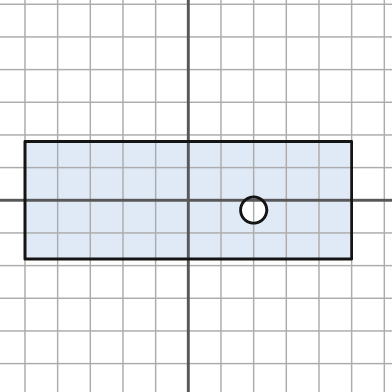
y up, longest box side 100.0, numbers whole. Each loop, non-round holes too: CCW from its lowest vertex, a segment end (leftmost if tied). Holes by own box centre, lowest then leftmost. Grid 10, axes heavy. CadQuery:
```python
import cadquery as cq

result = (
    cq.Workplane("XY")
    .moveTo(-50.0, -18.0)
    .lineTo(50.0, -18.0)
    .lineTo(50.0, 18.0)
    .lineTo(-50.0, 18.0)
    .close()
    .moveTo(20.0, -3.0)
    .circle(4.0)
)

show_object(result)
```